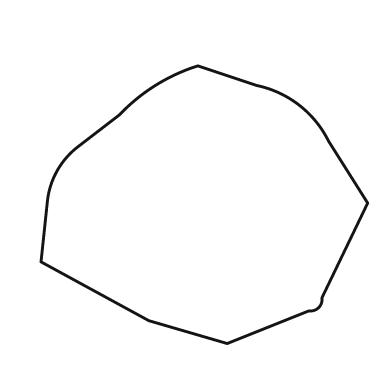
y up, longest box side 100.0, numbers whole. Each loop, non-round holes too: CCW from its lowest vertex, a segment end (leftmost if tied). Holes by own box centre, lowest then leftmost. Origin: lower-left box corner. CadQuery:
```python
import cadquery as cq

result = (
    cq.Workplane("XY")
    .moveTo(57.0, 0.0)
    .lineTo(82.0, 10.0)
    .threePointArc((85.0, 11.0), (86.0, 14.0))
    .lineTo(100.0, 43.0)
    .lineTo(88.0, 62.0)
    .threePointArc((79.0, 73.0), (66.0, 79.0))
    .lineTo(48.0, 85.0)
    .threePointArc((35.0, 79.0), (24.0, 70.0))
    .lineTo(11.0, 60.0)
    .threePointArc((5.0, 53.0), (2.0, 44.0))
    .lineTo(0.0, 25.0)
    .lineTo(33.0, 7.0)
    .close()
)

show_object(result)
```